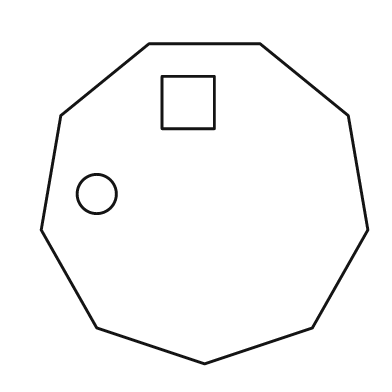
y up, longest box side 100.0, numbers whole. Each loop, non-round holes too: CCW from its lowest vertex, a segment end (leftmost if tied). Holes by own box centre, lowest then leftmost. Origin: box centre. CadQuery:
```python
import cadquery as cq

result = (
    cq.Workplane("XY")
    .moveTo(0.0, -49.0)
    .lineTo(33.0, -38.0)
    .lineTo(50.0, -8.0)
    .lineTo(44.0, 27.0)
    .lineTo(17.0, 49.0)
    .lineTo(-17.0, 49.0)
    .lineTo(-44.0, 27.0)
    .lineTo(-50.0, -8.0)
    .lineTo(-33.0, -38.0)
    .close()
    .moveTo(-33.0, 3.0)
    .circle(6.0)
    .moveTo(-13.0, 23.0)
    .lineTo(3.0, 23.0)
    .lineTo(3.0, 39.0)
    .lineTo(-13.0, 39.0)
    .close()
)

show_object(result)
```